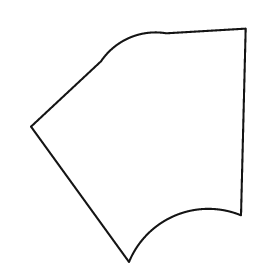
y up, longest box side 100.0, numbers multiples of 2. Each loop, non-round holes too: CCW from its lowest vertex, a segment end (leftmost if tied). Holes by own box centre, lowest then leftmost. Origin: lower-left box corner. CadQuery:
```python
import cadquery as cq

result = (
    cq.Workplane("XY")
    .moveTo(42.0, 0.0)
    .threePointArc((62.0, 20.0), (90.0, 20.0))
    .lineTo(92.0, 100.0)
    .lineTo(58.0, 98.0)
    .threePointArc((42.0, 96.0), (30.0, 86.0))
    .lineTo(0.0, 58.0)
    .close()
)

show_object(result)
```